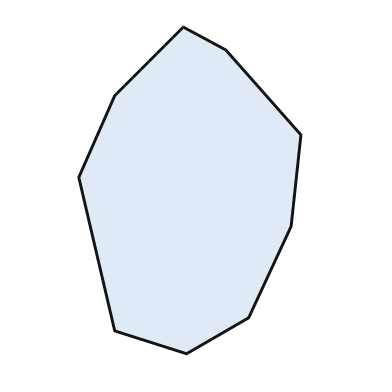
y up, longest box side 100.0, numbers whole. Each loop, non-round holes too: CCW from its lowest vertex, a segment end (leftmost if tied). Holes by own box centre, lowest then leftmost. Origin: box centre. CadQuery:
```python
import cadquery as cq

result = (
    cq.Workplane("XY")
    .moveTo(-1.0, -50.0)
    .lineTo(18.0, -39.0)
    .lineTo(31.0, -11.0)
    .lineTo(34.0, 17.0)
    .lineTo(11.0, 43.0)
    .lineTo(-2.0, 50.0)
    .lineTo(-23.0, 29.0)
    .lineTo(-34.0, 4.0)
    .lineTo(-23.0, -43.0)
    .close()
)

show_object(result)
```